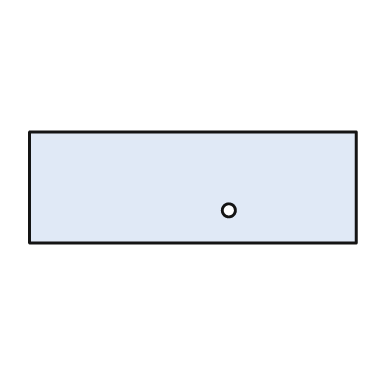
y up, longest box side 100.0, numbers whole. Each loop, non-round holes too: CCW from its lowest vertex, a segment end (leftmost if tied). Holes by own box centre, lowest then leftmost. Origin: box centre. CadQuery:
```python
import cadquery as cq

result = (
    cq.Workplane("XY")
    .moveTo(-50.0, -17.0)
    .lineTo(50.0, -17.0)
    .lineTo(50.0, 17.0)
    .lineTo(-50.0, 17.0)
    .close()
    .moveTo(11.0, -7.0)
    .circle(2.0)
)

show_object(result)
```